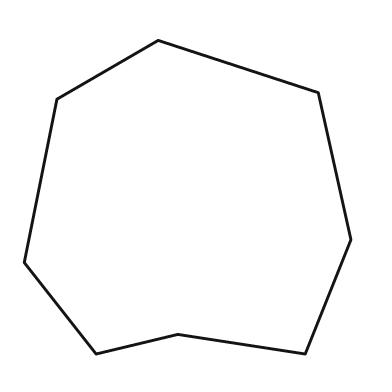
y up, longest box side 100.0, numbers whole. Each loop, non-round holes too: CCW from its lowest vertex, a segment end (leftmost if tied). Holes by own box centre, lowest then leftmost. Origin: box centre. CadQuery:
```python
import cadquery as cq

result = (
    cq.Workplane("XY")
    .moveTo(-28.0, -48.0)
    .lineTo(-3.0, -42.0)
    .lineTo(36.0, -48.0)
    .lineTo(50.0, -13.0)
    .lineTo(40.0, 32.0)
    .lineTo(-9.0, 48.0)
    .lineTo(-40.0, 30.0)
    .lineTo(-50.0, -20.0)
    .close()
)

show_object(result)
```